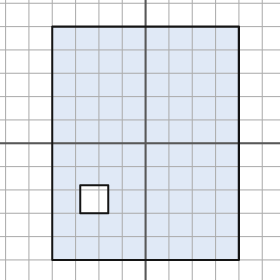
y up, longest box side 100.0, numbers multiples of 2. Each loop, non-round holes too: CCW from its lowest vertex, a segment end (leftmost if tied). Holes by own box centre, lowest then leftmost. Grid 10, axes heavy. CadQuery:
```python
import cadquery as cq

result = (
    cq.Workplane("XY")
    .moveTo(-40.0, -50.0)
    .lineTo(40.0, -50.0)
    .lineTo(40.0, 50.0)
    .lineTo(-40.0, 50.0)
    .close()
    .moveTo(-28.0, -30.0)
    .lineTo(-16.0, -30.0)
    .lineTo(-16.0, -18.0)
    .lineTo(-28.0, -18.0)
    .close()
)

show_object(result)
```